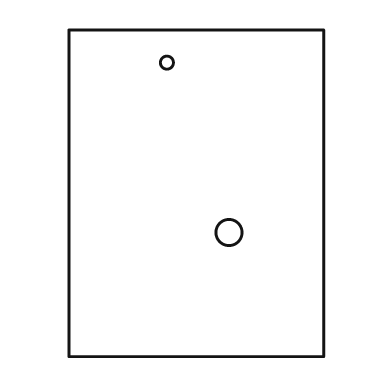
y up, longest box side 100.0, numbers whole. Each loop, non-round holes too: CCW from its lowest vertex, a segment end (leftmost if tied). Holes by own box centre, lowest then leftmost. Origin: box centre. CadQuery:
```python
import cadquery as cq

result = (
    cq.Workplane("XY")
    .moveTo(-39.0, -50.0)
    .lineTo(39.0, -50.0)
    .lineTo(39.0, 50.0)
    .lineTo(-39.0, 50.0)
    .close()
    .moveTo(10.0, -12.0)
    .circle(4.0)
    .moveTo(-9.0, 40.0)
    .circle(2.0)
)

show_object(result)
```